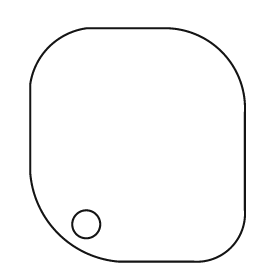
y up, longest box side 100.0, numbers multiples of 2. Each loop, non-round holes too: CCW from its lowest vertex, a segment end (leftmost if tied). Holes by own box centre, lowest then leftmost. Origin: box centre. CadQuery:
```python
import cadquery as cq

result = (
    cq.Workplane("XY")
    .moveTo(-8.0, -50.0)
    .lineTo(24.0, -50.0)
    .threePointArc((40.0, -44.0), (46.0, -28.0))
    .lineTo(46.0, 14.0)
    .threePointArc((36.0, 40.0), (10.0, 50.0))
    .lineTo(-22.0, 50.0)
    .threePointArc((-38.0, 42.0), (-46.0, 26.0))
    .lineTo(-46.0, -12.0)
    .threePointArc((-34.0, -38.0), (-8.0, -50.0))
    .close()
    .moveTo(-22.0, -34.0)
    .circle(6.0)
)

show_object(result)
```